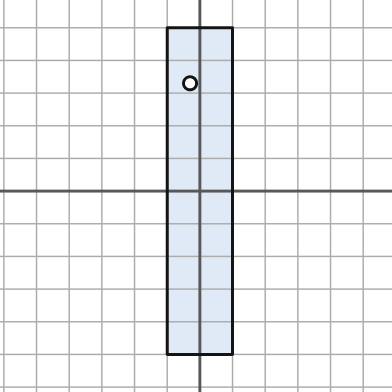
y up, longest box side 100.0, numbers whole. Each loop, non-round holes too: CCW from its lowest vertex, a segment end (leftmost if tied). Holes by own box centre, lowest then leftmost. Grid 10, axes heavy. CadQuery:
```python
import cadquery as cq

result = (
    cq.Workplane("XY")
    .moveTo(-10.0, -50.0)
    .lineTo(10.0, -50.0)
    .lineTo(10.0, 50.0)
    .lineTo(-10.0, 50.0)
    .close()
    .moveTo(-3.0, 33.0)
    .circle(2.0)
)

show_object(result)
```